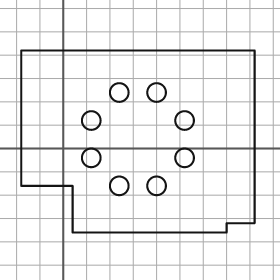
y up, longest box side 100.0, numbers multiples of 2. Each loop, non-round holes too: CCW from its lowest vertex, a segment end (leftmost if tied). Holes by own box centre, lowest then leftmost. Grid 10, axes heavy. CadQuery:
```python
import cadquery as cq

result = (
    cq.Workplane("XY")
    .moveTo(4.0, -36.0)
    .lineTo(70.0, -36.0)
    .lineTo(70.0, -32.0)
    .lineTo(82.0, -32.0)
    .lineTo(82.0, 42.0)
    .lineTo(-18.0, 42.0)
    .lineTo(-18.0, -16.0)
    .lineTo(4.0, -16.0)
    .close()
    .moveTo(24.0, -16.0)
    .circle(4.0)
    .moveTo(40.0, -16.0)
    .circle(4.0)
    .moveTo(12.0, -4.0)
    .circle(4.0)
    .moveTo(52.0, -4.0)
    .circle(4.0)
    .moveTo(12.0, 12.0)
    .circle(4.0)
    .moveTo(52.0, 12.0)
    .circle(4.0)
    .moveTo(24.0, 24.0)
    .circle(4.0)
    .moveTo(40.0, 24.0)
    .circle(4.0)
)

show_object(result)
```